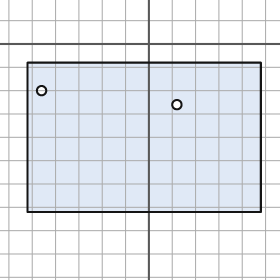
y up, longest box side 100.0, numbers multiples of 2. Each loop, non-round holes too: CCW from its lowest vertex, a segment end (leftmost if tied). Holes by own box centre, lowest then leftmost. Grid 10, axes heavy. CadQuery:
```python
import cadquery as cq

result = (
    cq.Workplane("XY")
    .moveTo(-52.0, -72.0)
    .lineTo(48.0, -72.0)
    .lineTo(48.0, -8.0)
    .lineTo(-52.0, -8.0)
    .close()
    .moveTo(12.0, -26.0)
    .circle(2.0)
    .moveTo(-46.0, -20.0)
    .circle(2.0)
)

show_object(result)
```